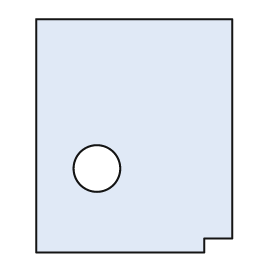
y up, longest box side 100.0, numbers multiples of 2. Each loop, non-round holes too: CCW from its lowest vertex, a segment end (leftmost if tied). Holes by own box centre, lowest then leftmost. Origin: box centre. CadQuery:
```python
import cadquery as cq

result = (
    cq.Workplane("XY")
    .moveTo(-42.0, -50.0)
    .lineTo(30.0, -50.0)
    .lineTo(30.0, -44.0)
    .lineTo(42.0, -44.0)
    .lineTo(42.0, 50.0)
    .lineTo(-42.0, 50.0)
    .close()
    .moveTo(-16.0, -14.0)
    .circle(10.0)
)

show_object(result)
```